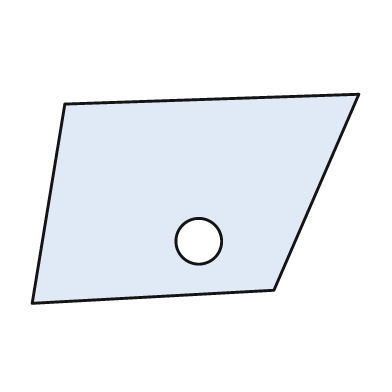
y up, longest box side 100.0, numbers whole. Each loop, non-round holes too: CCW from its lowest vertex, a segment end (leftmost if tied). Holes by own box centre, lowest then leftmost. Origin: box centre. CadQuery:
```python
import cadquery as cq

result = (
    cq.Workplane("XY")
    .moveTo(-50.0, -32.0)
    .lineTo(24.0, -28.0)
    .lineTo(50.0, 32.0)
    .lineTo(-40.0, 29.0)
    .close()
    .moveTo(1.0, -13.0)
    .circle(7.0)
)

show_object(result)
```